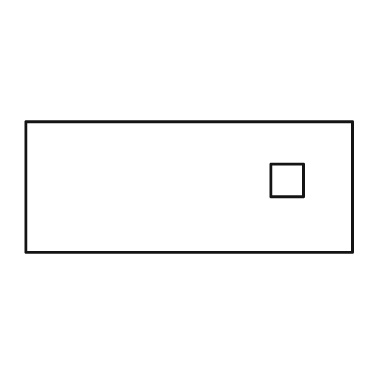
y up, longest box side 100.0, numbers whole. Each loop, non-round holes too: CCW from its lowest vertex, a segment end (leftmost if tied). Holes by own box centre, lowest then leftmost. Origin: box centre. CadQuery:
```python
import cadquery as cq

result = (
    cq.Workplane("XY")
    .moveTo(-50.0, -20.0)
    .lineTo(50.0, -20.0)
    .lineTo(50.0, 20.0)
    .lineTo(-50.0, 20.0)
    .close()
    .moveTo(25.0, -3.0)
    .lineTo(35.0, -3.0)
    .lineTo(35.0, 7.0)
    .lineTo(25.0, 7.0)
    .close()
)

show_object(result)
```